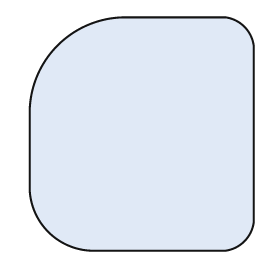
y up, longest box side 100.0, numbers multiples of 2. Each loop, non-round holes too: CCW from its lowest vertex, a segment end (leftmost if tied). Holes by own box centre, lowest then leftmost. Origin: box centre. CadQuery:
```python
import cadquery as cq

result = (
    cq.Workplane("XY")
    .moveTo(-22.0, -50.0)
    .lineTo(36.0, -50.0)
    .threePointArc((44.0, -46.0), (48.0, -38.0))
    .lineTo(48.0, 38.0)
    .threePointArc((44.0, 46.0), (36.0, 50.0))
    .lineTo(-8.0, 50.0)
    .threePointArc((-36.0, 38.0), (-48.0, 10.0))
    .lineTo(-48.0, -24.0)
    .threePointArc((-40.0, -42.0), (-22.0, -50.0))
    .close()
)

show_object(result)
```